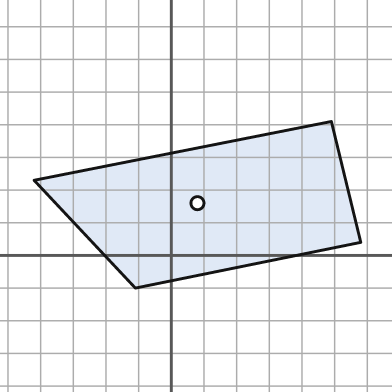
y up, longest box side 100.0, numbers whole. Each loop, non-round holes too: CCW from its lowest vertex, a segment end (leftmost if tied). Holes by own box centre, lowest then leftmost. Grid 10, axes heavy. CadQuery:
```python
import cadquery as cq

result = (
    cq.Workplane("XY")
    .moveTo(-11.0, -10.0)
    .lineTo(58.0, 4.0)
    .lineTo(49.0, 41.0)
    .lineTo(-42.0, 23.0)
    .close()
    .moveTo(8.0, 16.0)
    .circle(2.0)
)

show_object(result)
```